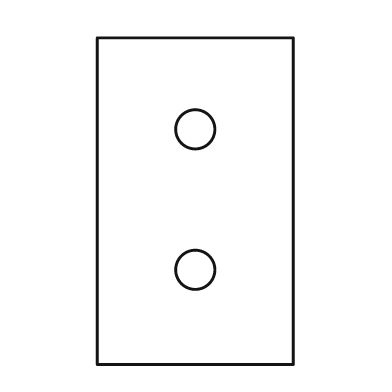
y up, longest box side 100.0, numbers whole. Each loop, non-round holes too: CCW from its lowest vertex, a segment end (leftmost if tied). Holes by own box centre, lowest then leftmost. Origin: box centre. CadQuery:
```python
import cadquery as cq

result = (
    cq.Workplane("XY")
    .moveTo(-30.0, -50.0)
    .lineTo(30.0, -50.0)
    .lineTo(30.0, 50.0)
    .lineTo(-30.0, 50.0)
    .close()
    .moveTo(0.0, -21.0)
    .circle(6.0)
    .moveTo(0.0, 22.0)
    .circle(6.0)
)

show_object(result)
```